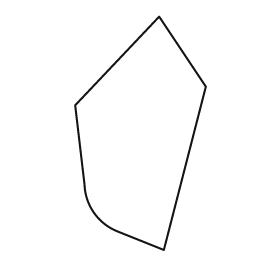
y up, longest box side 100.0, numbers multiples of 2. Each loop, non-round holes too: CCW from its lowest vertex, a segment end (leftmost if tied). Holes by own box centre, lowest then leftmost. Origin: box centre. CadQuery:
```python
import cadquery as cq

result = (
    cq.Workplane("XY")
    .moveTo(10.0, -50.0)
    .lineTo(28.0, 20.0)
    .lineTo(8.0, 50.0)
    .lineTo(-28.0, 12.0)
    .lineTo(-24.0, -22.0)
    .threePointArc((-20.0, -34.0), (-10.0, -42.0))
    .close()
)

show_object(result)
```